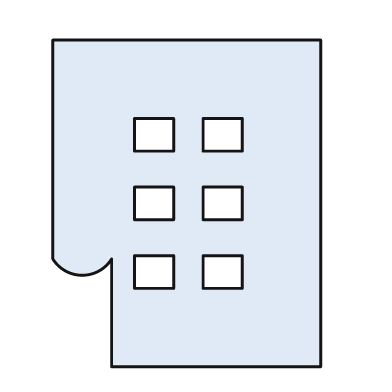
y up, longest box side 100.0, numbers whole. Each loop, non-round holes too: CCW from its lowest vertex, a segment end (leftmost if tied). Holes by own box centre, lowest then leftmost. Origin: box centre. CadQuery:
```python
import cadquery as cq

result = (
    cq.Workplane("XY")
    .moveTo(-23.0, -50.0)
    .lineTo(41.0, -50.0)
    .lineTo(41.0, 50.0)
    .lineTo(-41.0, 50.0)
    .lineTo(-41.0, -17.0)
    .threePointArc((-32.0, -22.0), (-23.0, -17.0))
    .close()
    .moveTo(-16.0, -26.0)
    .lineTo(-4.0, -26.0)
    .lineTo(-4.0, -16.0)
    .lineTo(-16.0, -16.0)
    .close()
    .moveTo(5.0, -26.0)
    .lineTo(17.0, -26.0)
    .lineTo(17.0, -16.0)
    .lineTo(5.0, -16.0)
    .close()
    .moveTo(-16.0, -5.0)
    .lineTo(-4.0, -5.0)
    .lineTo(-4.0, 5.0)
    .lineTo(-16.0, 5.0)
    .close()
    .moveTo(5.0, -5.0)
    .lineTo(17.0, -5.0)
    .lineTo(17.0, 5.0)
    .lineTo(5.0, 5.0)
    .close()
    .moveTo(-16.0, 16.0)
    .lineTo(-4.0, 16.0)
    .lineTo(-4.0, 26.0)
    .lineTo(-16.0, 26.0)
    .close()
    .moveTo(5.0, 16.0)
    .lineTo(17.0, 16.0)
    .lineTo(17.0, 26.0)
    .lineTo(5.0, 26.0)
    .close()
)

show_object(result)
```